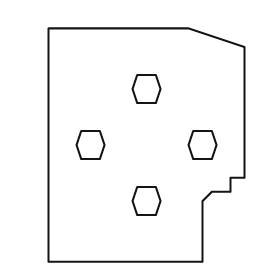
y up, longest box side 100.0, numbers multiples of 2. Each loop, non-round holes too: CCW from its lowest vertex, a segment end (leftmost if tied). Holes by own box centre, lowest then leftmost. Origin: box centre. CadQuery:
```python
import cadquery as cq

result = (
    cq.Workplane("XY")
    .moveTo(-42.0, -50.0)
    .lineTo(24.0, -50.0)
    .lineTo(24.0, -24.0)
    .lineTo(28.0, -20.0)
    .lineTo(36.0, -20.0)
    .lineTo(36.0, -14.0)
    .lineTo(42.0, -14.0)
    .lineTo(42.0, 42.0)
    .lineTo(18.0, 50.0)
    .lineTo(-42.0, 50.0)
    .close()
    .moveTo(-4.0, -30.0)
    .lineTo(4.0, -30.0)
    .lineTo(6.0, -24.0)
    .lineTo(4.0, -18.0)
    .lineTo(-4.0, -18.0)
    .lineTo(-6.0, -24.0)
    .close()
    .moveTo(-28.0, -6.0)
    .lineTo(-20.0, -6.0)
    .lineTo(-18.0, 0.0)
    .lineTo(-20.0, 6.0)
    .lineTo(-28.0, 6.0)
    .lineTo(-30.0, 0.0)
    .close()
    .moveTo(20.0, -6.0)
    .lineTo(28.0, -6.0)
    .lineTo(30.0, 0.0)
    .lineTo(28.0, 6.0)
    .lineTo(20.0, 6.0)
    .lineTo(18.0, 0.0)
    .close()
    .moveTo(-4.0, 18.0)
    .lineTo(4.0, 18.0)
    .lineTo(6.0, 24.0)
    .lineTo(4.0, 30.0)
    .lineTo(-4.0, 30.0)
    .lineTo(-6.0, 24.0)
    .close()
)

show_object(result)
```